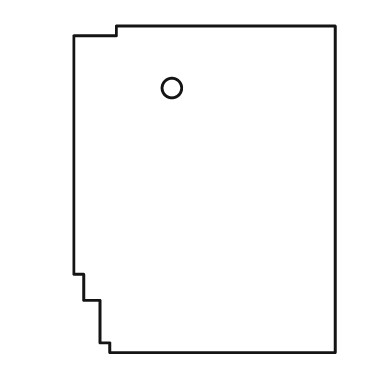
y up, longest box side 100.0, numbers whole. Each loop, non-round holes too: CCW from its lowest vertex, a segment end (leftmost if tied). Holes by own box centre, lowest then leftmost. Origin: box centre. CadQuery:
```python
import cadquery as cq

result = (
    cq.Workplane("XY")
    .moveTo(-29.0, -50.0)
    .lineTo(40.0, -50.0)
    .lineTo(40.0, 50.0)
    .lineTo(-27.0, 50.0)
    .lineTo(-27.0, 47.0)
    .lineTo(-40.0, 47.0)
    .lineTo(-40.0, -26.0)
    .lineTo(-37.0, -26.0)
    .lineTo(-37.0, -34.0)
    .lineTo(-32.0, -34.0)
    .lineTo(-32.0, -47.0)
    .lineTo(-29.0, -47.0)
    .close()
    .moveTo(-10.0, 31.0)
    .circle(3.0)
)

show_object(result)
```